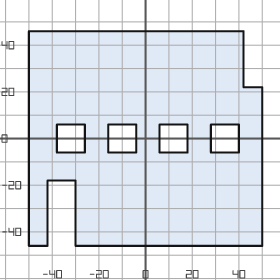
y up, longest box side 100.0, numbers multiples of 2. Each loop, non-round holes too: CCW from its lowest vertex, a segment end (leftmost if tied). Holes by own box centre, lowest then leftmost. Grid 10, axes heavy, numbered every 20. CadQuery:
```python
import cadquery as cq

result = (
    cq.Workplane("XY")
    .moveTo(-50.0, -46.0)
    .lineTo(-42.0, -46.0)
    .lineTo(-42.0, -18.0)
    .lineTo(-30.0, -18.0)
    .lineTo(-30.0, -46.0)
    .lineTo(50.0, -46.0)
    .lineTo(50.0, 22.0)
    .lineTo(42.0, 22.0)
    .lineTo(42.0, 46.0)
    .lineTo(-50.0, 46.0)
    .close()
    .moveTo(-38.0, -6.0)
    .lineTo(-26.0, -6.0)
    .lineTo(-26.0, 6.0)
    .lineTo(-38.0, 6.0)
    .close()
    .moveTo(-16.0, -6.0)
    .lineTo(-4.0, -6.0)
    .lineTo(-4.0, 6.0)
    .lineTo(-16.0, 6.0)
    .close()
    .moveTo(6.0, -6.0)
    .lineTo(18.0, -6.0)
    .lineTo(18.0, 6.0)
    .lineTo(6.0, 6.0)
    .close()
    .moveTo(28.0, -6.0)
    .lineTo(40.0, -6.0)
    .lineTo(40.0, 6.0)
    .lineTo(28.0, 6.0)
    .close()
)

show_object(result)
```